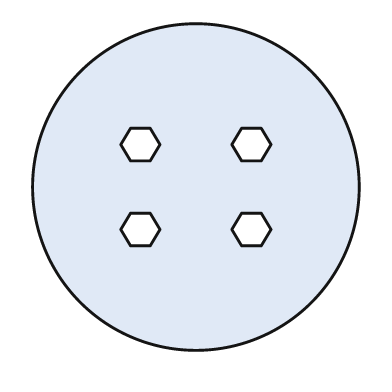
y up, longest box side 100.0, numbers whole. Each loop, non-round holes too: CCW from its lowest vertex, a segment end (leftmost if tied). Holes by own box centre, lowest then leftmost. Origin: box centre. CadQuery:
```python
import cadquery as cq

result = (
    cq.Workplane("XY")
    .moveTo(0.0, 0.0)
    .circle(50.0)
    .moveTo(-20.0, -18.0)
    .lineTo(-14.0, -18.0)
    .lineTo(-11.0, -13.0)
    .lineTo(-14.0, -8.0)
    .lineTo(-20.0, -8.0)
    .lineTo(-23.0, -13.0)
    .close()
    .moveTo(14.0, -18.0)
    .lineTo(20.0, -18.0)
    .lineTo(23.0, -13.0)
    .lineTo(20.0, -8.0)
    .lineTo(14.0, -8.0)
    .lineTo(11.0, -13.0)
    .close()
    .moveTo(-20.0, 8.0)
    .lineTo(-14.0, 8.0)
    .lineTo(-11.0, 13.0)
    .lineTo(-14.0, 18.0)
    .lineTo(-20.0, 18.0)
    .lineTo(-23.0, 13.0)
    .close()
    .moveTo(14.0, 8.0)
    .lineTo(20.0, 8.0)
    .lineTo(23.0, 13.0)
    .lineTo(20.0, 18.0)
    .lineTo(14.0, 18.0)
    .lineTo(11.0, 13.0)
    .close()
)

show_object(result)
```